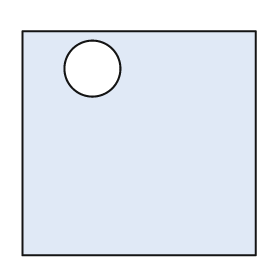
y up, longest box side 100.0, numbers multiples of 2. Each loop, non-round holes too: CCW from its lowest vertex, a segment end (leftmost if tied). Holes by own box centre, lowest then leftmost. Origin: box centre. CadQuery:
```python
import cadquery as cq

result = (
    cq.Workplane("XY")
    .moveTo(-50.0, -48.0)
    .lineTo(50.0, -48.0)
    .lineTo(50.0, 48.0)
    .lineTo(-50.0, 48.0)
    .close()
    .moveTo(-20.0, 32.0)
    .circle(12.0)
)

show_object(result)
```